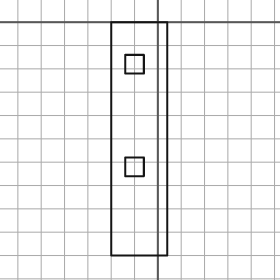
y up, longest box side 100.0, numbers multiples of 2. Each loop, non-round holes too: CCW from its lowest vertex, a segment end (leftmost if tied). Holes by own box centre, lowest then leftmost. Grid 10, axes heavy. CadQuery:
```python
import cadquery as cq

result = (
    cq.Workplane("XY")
    .moveTo(-20.0, -100.0)
    .lineTo(4.0, -100.0)
    .lineTo(4.0, 0.0)
    .lineTo(-20.0, 0.0)
    .close()
    .moveTo(-14.0, -66.0)
    .lineTo(-6.0, -66.0)
    .lineTo(-6.0, -58.0)
    .lineTo(-14.0, -58.0)
    .close()
    .moveTo(-14.0, -22.0)
    .lineTo(-6.0, -22.0)
    .lineTo(-6.0, -14.0)
    .lineTo(-14.0, -14.0)
    .close()
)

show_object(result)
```